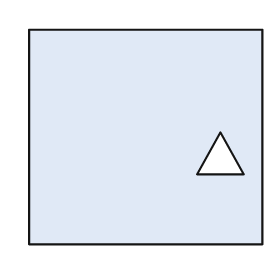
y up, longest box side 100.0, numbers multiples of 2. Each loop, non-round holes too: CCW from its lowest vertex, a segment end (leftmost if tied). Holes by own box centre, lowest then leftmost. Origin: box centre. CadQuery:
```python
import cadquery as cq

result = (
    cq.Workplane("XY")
    .moveTo(-50.0, -46.0)
    .lineTo(50.0, -46.0)
    .lineTo(50.0, 46.0)
    .lineTo(-50.0, 46.0)
    .close()
    .moveTo(22.0, -16.0)
    .lineTo(42.0, -16.0)
    .lineTo(32.0, 2.0)
    .close()
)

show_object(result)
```